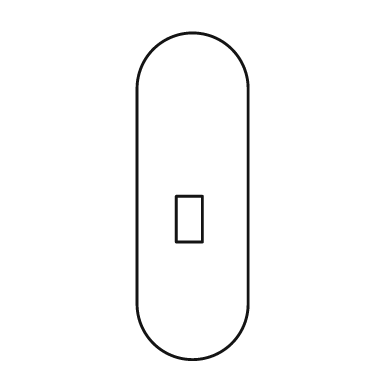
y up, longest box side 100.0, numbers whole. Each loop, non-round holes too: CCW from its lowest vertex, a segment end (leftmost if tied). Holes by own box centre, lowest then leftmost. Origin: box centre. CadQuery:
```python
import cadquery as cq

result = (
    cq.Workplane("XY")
    .moveTo(-17.0, -33.0)
    .threePointArc((0.0, -50.0), (17.0, -33.0))
    .lineTo(17.0, 33.0)
    .threePointArc((0.0, 50.0), (-17.0, 33.0))
    .close()
    .moveTo(-5.0, -14.0)
    .lineTo(3.0, -14.0)
    .lineTo(3.0, 0.0)
    .lineTo(-5.0, 0.0)
    .close()
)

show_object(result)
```